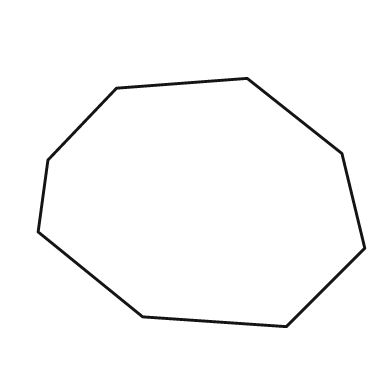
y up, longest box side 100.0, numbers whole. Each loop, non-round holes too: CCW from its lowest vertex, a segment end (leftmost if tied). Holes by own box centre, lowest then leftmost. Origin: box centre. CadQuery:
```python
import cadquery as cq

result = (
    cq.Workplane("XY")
    .moveTo(26.0, -38.0)
    .lineTo(50.0, -14.0)
    .lineTo(43.0, 15.0)
    .lineTo(14.0, 38.0)
    .lineTo(-26.0, 35.0)
    .lineTo(-47.0, 13.0)
    .lineTo(-50.0, -9.0)
    .lineTo(-18.0, -35.0)
    .close()
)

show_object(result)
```